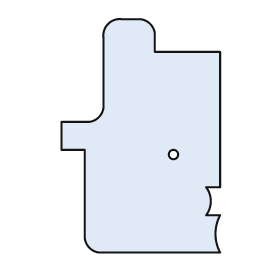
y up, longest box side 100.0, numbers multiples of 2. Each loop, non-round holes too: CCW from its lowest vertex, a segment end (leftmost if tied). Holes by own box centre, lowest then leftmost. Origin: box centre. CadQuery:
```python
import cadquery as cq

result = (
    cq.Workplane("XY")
    .moveTo(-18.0, -50.0)
    .lineTo(34.0, -50.0)
    .threePointArc((32.0, -42.0), (34.0, -34.0))
    .lineTo(28.0, -34.0)
    .threePointArc((30.0, -28.0), (28.0, -22.0))
    .lineTo(34.0, -22.0)
    .lineTo(34.0, 36.0)
    .lineTo(6.0, 36.0)
    .lineTo(6.0, 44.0)
    .threePointArc((4.0, 48.0), (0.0, 50.0))
    .lineTo(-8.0, 50.0)
    .threePointArc((-14.0, 48.0), (-16.0, 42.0))
    .lineTo(-16.0, 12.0)
    .threePointArc((-18.0, 8.0), (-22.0, 6.0))
    .lineTo(-34.0, 6.0)
    .lineTo(-34.0, -6.0)
    .lineTo(-24.0, -6.0)
    .lineTo(-24.0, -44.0)
    .threePointArc((-22.0, -48.0), (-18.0, -50.0))
    .close()
    .moveTo(14.0, -8.0)
    .circle(2.0)
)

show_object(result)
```